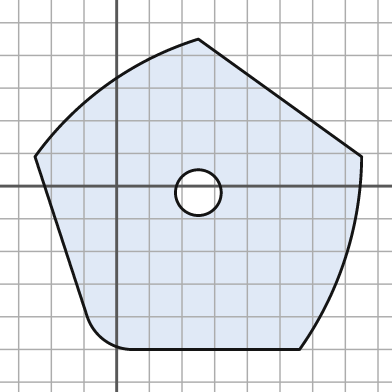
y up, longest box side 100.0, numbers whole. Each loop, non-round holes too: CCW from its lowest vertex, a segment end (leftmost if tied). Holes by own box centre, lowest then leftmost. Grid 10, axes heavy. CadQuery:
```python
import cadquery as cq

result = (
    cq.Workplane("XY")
    .moveTo(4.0, -50.0)
    .lineTo(56.0, -50.0)
    .threePointArc((70.0, -22.0), (75.0, 9.0))
    .lineTo(25.0, 45.0)
    .threePointArc((-3.0, 31.0), (-25.0, 9.0))
    .lineTo(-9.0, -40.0)
    .threePointArc((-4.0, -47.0), (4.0, -50.0))
    .close()
    .moveTo(25.0, -2.0)
    .circle(7.0)
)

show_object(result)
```